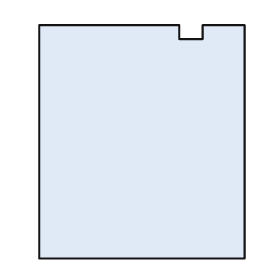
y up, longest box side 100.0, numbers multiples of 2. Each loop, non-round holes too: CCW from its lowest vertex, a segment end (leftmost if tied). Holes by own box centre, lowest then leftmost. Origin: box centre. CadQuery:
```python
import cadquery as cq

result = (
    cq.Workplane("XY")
    .moveTo(-44.0, -50.0)
    .lineTo(44.0, -50.0)
    .lineTo(44.0, 50.0)
    .lineTo(26.0, 50.0)
    .lineTo(26.0, 44.0)
    .lineTo(16.0, 44.0)
    .lineTo(16.0, 50.0)
    .lineTo(-44.0, 50.0)
    .close()
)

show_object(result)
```